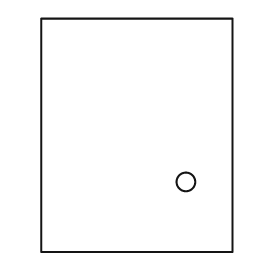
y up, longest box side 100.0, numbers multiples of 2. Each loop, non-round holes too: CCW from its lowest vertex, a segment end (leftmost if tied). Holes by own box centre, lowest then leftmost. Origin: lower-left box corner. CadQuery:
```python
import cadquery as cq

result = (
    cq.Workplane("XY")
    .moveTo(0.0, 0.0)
    .lineTo(82.0, 0.0)
    .lineTo(82.0, 100.0)
    .lineTo(0.0, 100.0)
    .close()
    .moveTo(62.0, 30.0)
    .circle(4.0)
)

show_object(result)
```